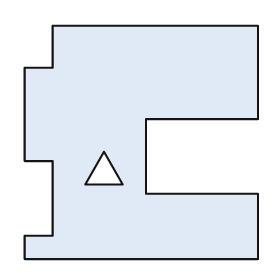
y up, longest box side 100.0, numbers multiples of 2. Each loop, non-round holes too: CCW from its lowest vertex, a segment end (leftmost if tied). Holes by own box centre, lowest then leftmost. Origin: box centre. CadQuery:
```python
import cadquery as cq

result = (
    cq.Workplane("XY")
    .moveTo(-50.0, -50.0)
    .lineTo(50.0, -50.0)
    .lineTo(50.0, -22.0)
    .lineTo(2.0, -22.0)
    .lineTo(2.0, 10.0)
    .lineTo(50.0, 10.0)
    .lineTo(50.0, 50.0)
    .lineTo(-38.0, 50.0)
    .lineTo(-38.0, 32.0)
    .lineTo(-50.0, 32.0)
    .lineTo(-50.0, -8.0)
    .lineTo(-38.0, -8.0)
    .lineTo(-38.0, -40.0)
    .lineTo(-50.0, -40.0)
    .close()
    .moveTo(-24.0, -18.0)
    .lineTo(-8.0, -18.0)
    .lineTo(-16.0, -4.0)
    .close()
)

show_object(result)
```